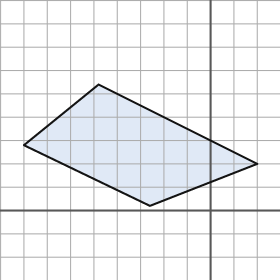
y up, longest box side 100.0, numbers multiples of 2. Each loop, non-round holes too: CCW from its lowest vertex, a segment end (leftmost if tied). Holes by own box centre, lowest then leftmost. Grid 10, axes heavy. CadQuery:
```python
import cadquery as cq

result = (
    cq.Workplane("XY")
    .moveTo(-26.0, 2.0)
    .lineTo(20.0, 20.0)
    .lineTo(-48.0, 54.0)
    .lineTo(-80.0, 28.0)
    .close()
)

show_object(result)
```